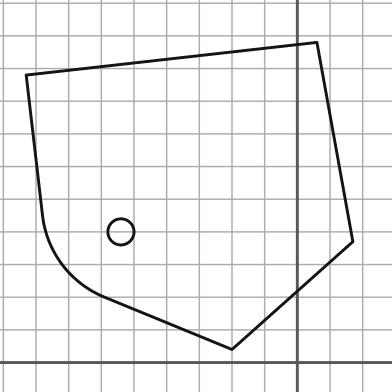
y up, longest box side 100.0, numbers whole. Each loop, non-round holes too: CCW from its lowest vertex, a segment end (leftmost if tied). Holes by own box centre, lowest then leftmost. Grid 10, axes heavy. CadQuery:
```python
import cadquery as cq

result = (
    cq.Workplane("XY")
    .moveTo(-20.0, 4.0)
    .lineTo(17.0, 37.0)
    .lineTo(6.0, 98.0)
    .lineTo(-83.0, 88.0)
    .lineTo(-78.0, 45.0)
    .threePointArc((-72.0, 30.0), (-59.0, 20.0))
    .close()
    .moveTo(-54.0, 40.0)
    .circle(4.0)
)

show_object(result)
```